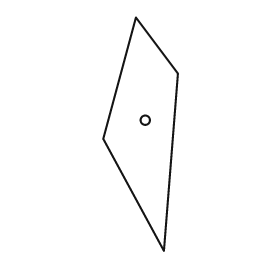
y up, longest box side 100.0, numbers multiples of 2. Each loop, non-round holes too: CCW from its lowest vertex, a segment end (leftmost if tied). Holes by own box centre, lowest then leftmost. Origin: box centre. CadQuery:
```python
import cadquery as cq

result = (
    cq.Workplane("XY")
    .moveTo(10.0, -50.0)
    .lineTo(16.0, 26.0)
    .lineTo(-2.0, 50.0)
    .lineTo(-16.0, -2.0)
    .close()
    .moveTo(2.0, 6.0)
    .circle(2.0)
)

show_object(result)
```